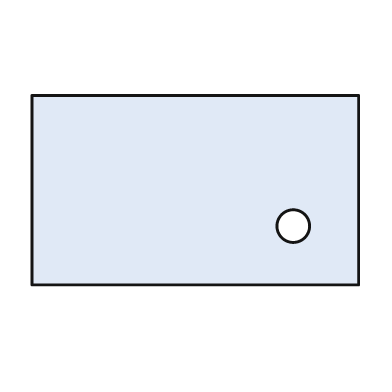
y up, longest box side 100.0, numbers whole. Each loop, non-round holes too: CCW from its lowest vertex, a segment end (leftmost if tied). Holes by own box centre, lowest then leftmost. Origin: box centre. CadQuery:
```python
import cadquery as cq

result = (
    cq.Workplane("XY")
    .moveTo(-50.0, -29.0)
    .lineTo(50.0, -29.0)
    .lineTo(50.0, 29.0)
    .lineTo(-50.0, 29.0)
    .close()
    .moveTo(30.0, -11.0)
    .circle(5.0)
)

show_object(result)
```